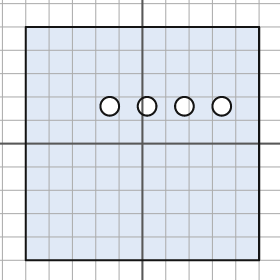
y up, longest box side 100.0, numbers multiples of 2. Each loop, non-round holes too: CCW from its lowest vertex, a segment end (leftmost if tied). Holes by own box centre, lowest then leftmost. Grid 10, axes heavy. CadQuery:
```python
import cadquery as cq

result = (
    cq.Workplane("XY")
    .moveTo(-50.0, -50.0)
    .lineTo(50.0, -50.0)
    .lineTo(50.0, 50.0)
    .lineTo(-50.0, 50.0)
    .close()
    .moveTo(-14.0, 16.0)
    .circle(4.0)
    .moveTo(2.0, 16.0)
    .circle(4.0)
    .moveTo(18.0, 16.0)
    .circle(4.0)
    .moveTo(34.0, 16.0)
    .circle(4.0)
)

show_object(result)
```